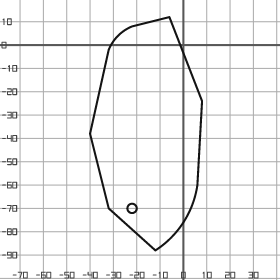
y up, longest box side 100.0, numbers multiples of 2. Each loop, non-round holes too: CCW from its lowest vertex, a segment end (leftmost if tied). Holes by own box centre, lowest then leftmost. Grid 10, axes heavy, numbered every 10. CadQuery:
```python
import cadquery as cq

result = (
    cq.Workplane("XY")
    .moveTo(-12.0, -88.0)
    .threePointArc((0.0, -76.0), (6.0, -60.0))
    .lineTo(8.0, -24.0)
    .lineTo(-6.0, 12.0)
    .lineTo(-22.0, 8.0)
    .threePointArc((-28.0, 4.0), (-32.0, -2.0))
    .lineTo(-40.0, -38.0)
    .lineTo(-32.0, -70.0)
    .close()
    .moveTo(-22.0, -70.0)
    .circle(2.0)
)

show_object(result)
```